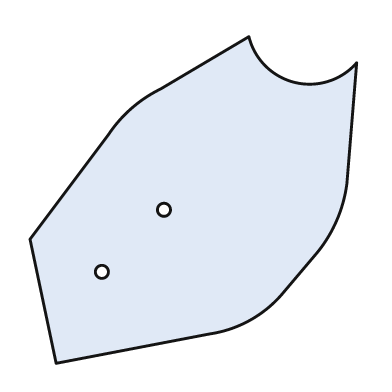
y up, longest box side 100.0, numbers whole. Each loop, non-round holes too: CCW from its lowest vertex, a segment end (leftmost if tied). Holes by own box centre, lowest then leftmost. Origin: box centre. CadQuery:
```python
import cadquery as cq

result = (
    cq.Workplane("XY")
    .moveTo(-42.0, -50.0)
    .lineTo(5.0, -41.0)
    .threePointArc((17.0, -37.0), (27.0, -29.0))
    .lineTo(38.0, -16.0)
    .threePointArc((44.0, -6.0), (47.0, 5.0))
    .lineTo(50.0, 42.0)
    .threePointArc((31.0, 36.0), (17.0, 50.0))
    .lineTo(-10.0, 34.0)
    .threePointArc((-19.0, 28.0), (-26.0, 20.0))
    .lineTo(-50.0, -12.0)
    .close()
    .moveTo(-28.0, -22.0)
    .circle(2.0)
    .moveTo(-9.0, -3.0)
    .circle(2.0)
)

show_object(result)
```